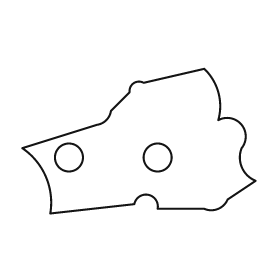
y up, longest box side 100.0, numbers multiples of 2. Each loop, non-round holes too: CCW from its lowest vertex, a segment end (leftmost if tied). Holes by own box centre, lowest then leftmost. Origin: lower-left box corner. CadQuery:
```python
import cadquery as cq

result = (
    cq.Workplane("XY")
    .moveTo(12.0, 0.0)
    .lineTo(48.0, 4.0)
    .threePointArc((54.0, 8.0), (58.0, 2.0))
    .lineTo(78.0, 2.0)
    .threePointArc((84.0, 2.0), (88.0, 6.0))
    .lineTo(100.0, 14.0)
    .threePointArc((94.0, 20.0), (94.0, 28.0))
    .threePointArc((94.0, 38.0), (84.0, 40.0))
    .threePointArc((84.0, 52.0), (78.0, 62.0))
    .lineTo(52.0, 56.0)
    .threePointArc((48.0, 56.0), (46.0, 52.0))
    .lineTo(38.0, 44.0)
    .threePointArc((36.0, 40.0), (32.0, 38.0))
    .lineTo(0.0, 28.0)
    .threePointArc((10.0, 16.0), (12.0, 0.0))
    .close()
    .moveTo(20.0, 24.0)
    .circle(6.0)
    .moveTo(58.0, 24.0)
    .circle(6.0)
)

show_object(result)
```